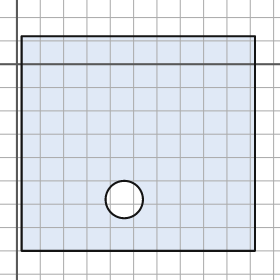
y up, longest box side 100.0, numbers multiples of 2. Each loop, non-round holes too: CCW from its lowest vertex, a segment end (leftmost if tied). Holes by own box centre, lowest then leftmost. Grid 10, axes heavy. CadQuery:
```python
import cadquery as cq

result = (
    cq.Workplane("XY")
    .moveTo(2.0, -80.0)
    .lineTo(102.0, -80.0)
    .lineTo(102.0, 12.0)
    .lineTo(2.0, 12.0)
    .close()
    .moveTo(46.0, -58.0)
    .circle(8.0)
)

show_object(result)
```